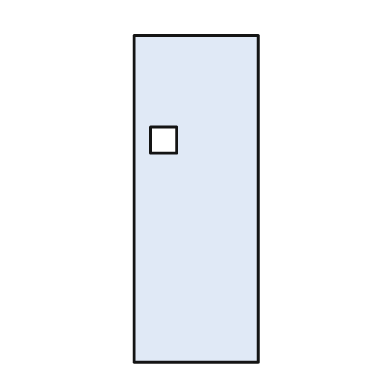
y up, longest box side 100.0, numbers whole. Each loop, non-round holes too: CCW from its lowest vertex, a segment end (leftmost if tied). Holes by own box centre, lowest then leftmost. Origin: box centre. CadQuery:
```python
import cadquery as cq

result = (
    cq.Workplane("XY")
    .moveTo(-19.0, -50.0)
    .lineTo(19.0, -50.0)
    .lineTo(19.0, 50.0)
    .lineTo(-19.0, 50.0)
    .close()
    .moveTo(-14.0, 14.0)
    .lineTo(-6.0, 14.0)
    .lineTo(-6.0, 22.0)
    .lineTo(-14.0, 22.0)
    .close()
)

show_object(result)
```